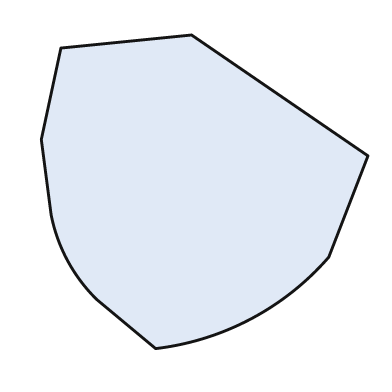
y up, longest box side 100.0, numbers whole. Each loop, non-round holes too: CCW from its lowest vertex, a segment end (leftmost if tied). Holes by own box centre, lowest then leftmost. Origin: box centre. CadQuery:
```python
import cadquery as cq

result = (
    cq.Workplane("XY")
    .moveTo(-15.0, -48.0)
    .threePointArc((14.0, -39.0), (38.0, -20.0))
    .lineTo(50.0, 11.0)
    .lineTo(-4.0, 48.0)
    .lineTo(-44.0, 44.0)
    .lineTo(-50.0, 16.0)
    .lineTo(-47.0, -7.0)
    .threePointArc((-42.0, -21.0), (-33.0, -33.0))
    .close()
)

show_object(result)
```